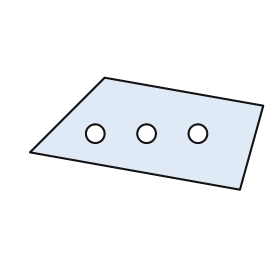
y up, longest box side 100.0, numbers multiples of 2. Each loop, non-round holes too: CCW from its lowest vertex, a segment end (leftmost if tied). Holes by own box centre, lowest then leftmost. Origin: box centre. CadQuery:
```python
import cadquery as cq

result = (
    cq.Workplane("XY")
    .moveTo(40.0, -24.0)
    .lineTo(50.0, 12.0)
    .lineTo(-18.0, 24.0)
    .lineTo(-50.0, -8.0)
    .close()
    .moveTo(-22.0, 0.0)
    .circle(4.0)
    .moveTo(0.0, 0.0)
    .circle(4.0)
    .moveTo(22.0, 0.0)
    .circle(4.0)
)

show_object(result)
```